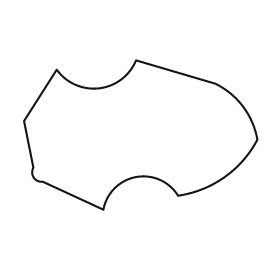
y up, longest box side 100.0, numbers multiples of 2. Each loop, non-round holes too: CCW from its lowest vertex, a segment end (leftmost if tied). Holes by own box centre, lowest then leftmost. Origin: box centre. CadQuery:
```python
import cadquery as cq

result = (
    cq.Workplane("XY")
    .moveTo(-16.0, -32.0)
    .threePointArc((-2.0, -18.0), (16.0, -26.0))
    .threePointArc((36.0, -18.0), (50.0, -2.0))
    .threePointArc((44.0, 12.0), (32.0, 22.0))
    .lineTo(-2.0, 32.0)
    .threePointArc((-18.0, 20.0), (-36.0, 28.0))
    .lineTo(-50.0, 6.0)
    .lineTo(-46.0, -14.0)
    .threePointArc((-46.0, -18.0), (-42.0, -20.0))
    .close()
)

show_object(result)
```